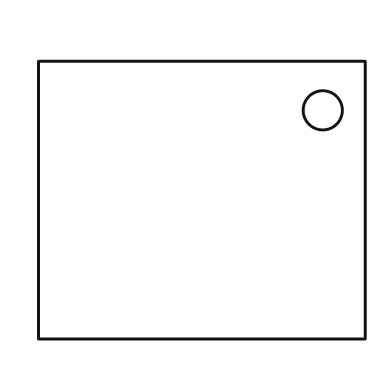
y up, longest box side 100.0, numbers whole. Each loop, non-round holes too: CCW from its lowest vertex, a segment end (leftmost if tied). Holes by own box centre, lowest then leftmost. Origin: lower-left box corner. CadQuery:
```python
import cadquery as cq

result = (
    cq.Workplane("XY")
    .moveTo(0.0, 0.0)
    .lineTo(100.0, 0.0)
    .lineTo(100.0, 85.0)
    .lineTo(0.0, 85.0)
    .close()
    .moveTo(87.0, 70.0)
    .circle(6.0)
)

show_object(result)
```